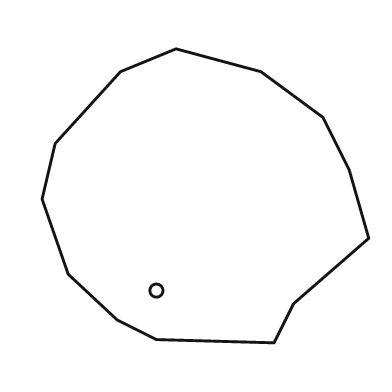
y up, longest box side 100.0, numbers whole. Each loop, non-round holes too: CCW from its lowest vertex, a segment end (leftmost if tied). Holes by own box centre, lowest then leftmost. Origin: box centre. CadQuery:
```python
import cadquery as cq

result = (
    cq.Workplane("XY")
    .moveTo(21.0, -45.0)
    .lineTo(27.0, -33.0)
    .lineTo(50.0, -13.0)
    .lineTo(44.0, 8.0)
    .lineTo(36.0, 24.0)
    .lineTo(17.0, 38.0)
    .lineTo(-9.0, 45.0)
    .lineTo(-26.0, 38.0)
    .lineTo(-46.0, 16.0)
    .lineTo(-50.0, -1.0)
    .lineTo(-42.0, -24.0)
    .lineTo(-27.0, -38.0)
    .lineTo(-15.0, -44.0)
    .close()
    .moveTo(-15.0, -29.0)
    .circle(2.0)
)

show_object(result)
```